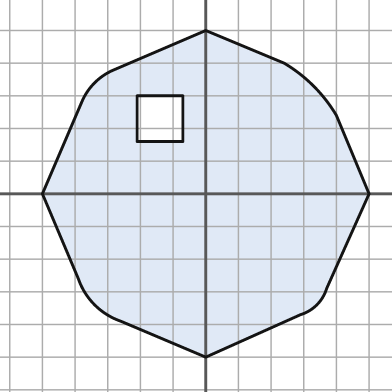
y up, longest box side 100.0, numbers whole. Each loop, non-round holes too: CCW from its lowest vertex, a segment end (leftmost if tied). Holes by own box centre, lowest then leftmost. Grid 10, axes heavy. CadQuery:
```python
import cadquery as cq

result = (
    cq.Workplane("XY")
    .moveTo(0.0, -50.0)
    .lineTo(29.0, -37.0)
    .threePointArc((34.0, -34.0), (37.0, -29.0))
    .lineTo(50.0, 0.0)
    .lineTo(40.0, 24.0)
    .threePointArc((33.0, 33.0), (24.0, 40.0))
    .lineTo(0.0, 50.0)
    .lineTo(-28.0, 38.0)
    .threePointArc((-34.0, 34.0), (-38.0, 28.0))
    .lineTo(-50.0, 0.0)
    .lineTo(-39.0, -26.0)
    .threePointArc((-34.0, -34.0), (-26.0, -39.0))
    .close()
    .moveTo(-21.0, 16.0)
    .lineTo(-7.0, 16.0)
    .lineTo(-7.0, 30.0)
    .lineTo(-21.0, 30.0)
    .close()
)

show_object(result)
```